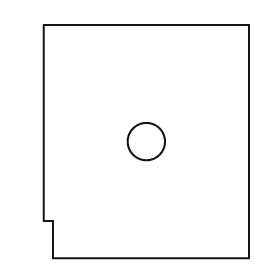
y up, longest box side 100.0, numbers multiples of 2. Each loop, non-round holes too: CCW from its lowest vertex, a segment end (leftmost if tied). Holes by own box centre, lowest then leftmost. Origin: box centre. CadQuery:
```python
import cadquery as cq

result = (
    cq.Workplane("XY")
    .moveTo(-40.0, -50.0)
    .lineTo(44.0, -50.0)
    .lineTo(44.0, 50.0)
    .lineTo(-44.0, 50.0)
    .lineTo(-44.0, -34.0)
    .lineTo(-40.0, -34.0)
    .close()
    .moveTo(0.0, 0.0)
    .circle(8.0)
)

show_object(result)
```